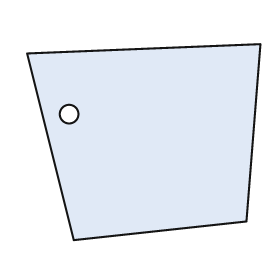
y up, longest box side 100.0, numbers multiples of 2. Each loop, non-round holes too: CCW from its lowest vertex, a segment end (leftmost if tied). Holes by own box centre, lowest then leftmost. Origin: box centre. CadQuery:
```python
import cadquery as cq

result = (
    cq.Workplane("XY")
    .moveTo(-30.0, -42.0)
    .lineTo(44.0, -34.0)
    .lineTo(50.0, 42.0)
    .lineTo(-50.0, 38.0)
    .close()
    .moveTo(-32.0, 12.0)
    .circle(4.0)
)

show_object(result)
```